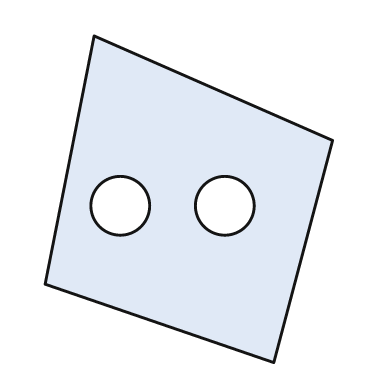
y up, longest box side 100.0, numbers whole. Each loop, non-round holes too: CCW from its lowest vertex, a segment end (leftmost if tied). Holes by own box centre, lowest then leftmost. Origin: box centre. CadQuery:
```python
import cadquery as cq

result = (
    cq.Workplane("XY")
    .moveTo(26.0, -50.0)
    .lineTo(44.0, 18.0)
    .lineTo(-29.0, 50.0)
    .lineTo(-44.0, -26.0)
    .close()
    .moveTo(-21.0, -2.0)
    .circle(9.0)
    .moveTo(11.0, -2.0)
    .circle(9.0)
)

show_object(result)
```